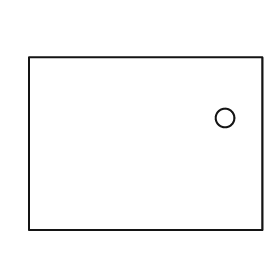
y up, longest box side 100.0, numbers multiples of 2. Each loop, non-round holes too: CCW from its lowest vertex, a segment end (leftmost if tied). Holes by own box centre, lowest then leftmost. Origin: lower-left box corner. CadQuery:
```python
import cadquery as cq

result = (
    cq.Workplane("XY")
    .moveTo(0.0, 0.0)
    .lineTo(100.0, 0.0)
    .lineTo(100.0, 74.0)
    .lineTo(0.0, 74.0)
    .close()
    .moveTo(84.0, 48.0)
    .circle(4.0)
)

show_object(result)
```